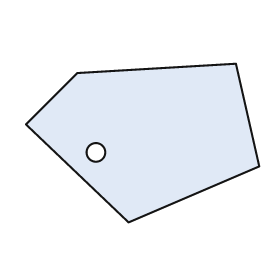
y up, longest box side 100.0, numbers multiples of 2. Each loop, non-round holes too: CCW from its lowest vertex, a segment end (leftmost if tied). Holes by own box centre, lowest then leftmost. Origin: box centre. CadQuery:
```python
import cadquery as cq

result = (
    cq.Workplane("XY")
    .moveTo(-6.0, -34.0)
    .lineTo(50.0, -10.0)
    .lineTo(40.0, 34.0)
    .lineTo(-28.0, 30.0)
    .lineTo(-50.0, 8.0)
    .close()
    .moveTo(-20.0, -4.0)
    .circle(4.0)
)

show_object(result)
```